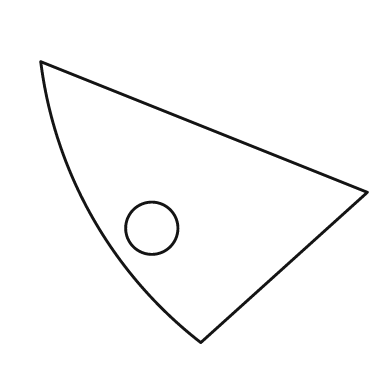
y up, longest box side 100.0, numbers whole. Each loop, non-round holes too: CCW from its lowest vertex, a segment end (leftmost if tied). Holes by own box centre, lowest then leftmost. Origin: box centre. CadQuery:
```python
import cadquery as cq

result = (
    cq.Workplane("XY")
    .moveTo(-1.0, -43.0)
    .lineTo(50.0, 3.0)
    .lineTo(-50.0, 43.0)
    .threePointArc((-34.0, -5.0), (-1.0, -43.0))
    .close()
    .moveTo(-16.0, -8.0)
    .circle(8.0)
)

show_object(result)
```